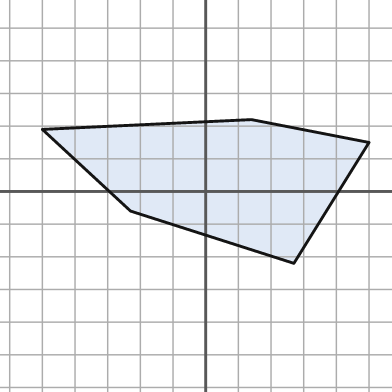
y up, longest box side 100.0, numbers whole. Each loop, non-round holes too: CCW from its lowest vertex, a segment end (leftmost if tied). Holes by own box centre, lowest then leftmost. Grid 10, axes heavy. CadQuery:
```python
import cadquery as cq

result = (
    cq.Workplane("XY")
    .moveTo(27.0, -22.0)
    .lineTo(50.0, 15.0)
    .lineTo(14.0, 22.0)
    .lineTo(-50.0, 19.0)
    .lineTo(-23.0, -6.0)
    .close()
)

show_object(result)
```